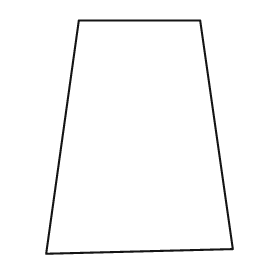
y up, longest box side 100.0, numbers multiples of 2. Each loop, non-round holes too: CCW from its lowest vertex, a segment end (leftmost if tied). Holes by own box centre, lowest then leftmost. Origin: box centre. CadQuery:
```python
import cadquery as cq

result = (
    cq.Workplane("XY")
    .moveTo(-40.0, -50.0)
    .lineTo(40.0, -48.0)
    .lineTo(26.0, 50.0)
    .lineTo(-26.0, 50.0)
    .close()
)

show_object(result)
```